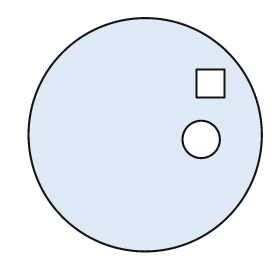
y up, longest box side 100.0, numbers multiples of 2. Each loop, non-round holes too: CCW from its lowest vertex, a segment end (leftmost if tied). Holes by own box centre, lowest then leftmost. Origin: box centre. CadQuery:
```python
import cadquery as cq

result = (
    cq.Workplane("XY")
    .moveTo(0.0, 0.0)
    .circle(50.0)
    .moveTo(24.0, -2.0)
    .circle(8.0)
    .moveTo(22.0, 16.0)
    .lineTo(34.0, 16.0)
    .lineTo(34.0, 28.0)
    .lineTo(22.0, 28.0)
    .close()
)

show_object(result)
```